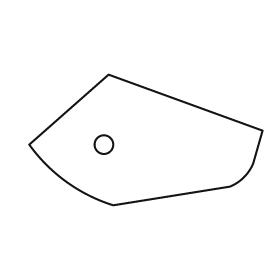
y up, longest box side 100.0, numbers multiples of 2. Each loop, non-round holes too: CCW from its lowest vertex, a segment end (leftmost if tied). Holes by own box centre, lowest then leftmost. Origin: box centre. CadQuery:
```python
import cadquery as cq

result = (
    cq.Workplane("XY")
    .moveTo(-14.0, -28.0)
    .lineTo(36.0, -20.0)
    .threePointArc((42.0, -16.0), (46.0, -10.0))
    .lineTo(50.0, 4.0)
    .lineTo(-16.0, 28.0)
    .lineTo(-50.0, -2.0)
    .threePointArc((-34.0, -18.0), (-14.0, -28.0))
    .close()
    .moveTo(-18.0, -2.0)
    .circle(4.0)
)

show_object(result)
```